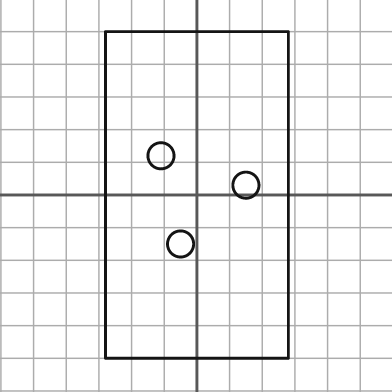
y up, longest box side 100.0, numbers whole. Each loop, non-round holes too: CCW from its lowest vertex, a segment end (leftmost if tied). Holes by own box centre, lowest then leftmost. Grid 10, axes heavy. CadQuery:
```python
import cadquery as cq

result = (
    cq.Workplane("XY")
    .moveTo(-28.0, -50.0)
    .lineTo(28.0, -50.0)
    .lineTo(28.0, 50.0)
    .lineTo(-28.0, 50.0)
    .close()
    .moveTo(-5.0, -15.0)
    .circle(4.0)
    .moveTo(15.0, 3.0)
    .circle(4.0)
    .moveTo(-11.0, 12.0)
    .circle(4.0)
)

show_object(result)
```